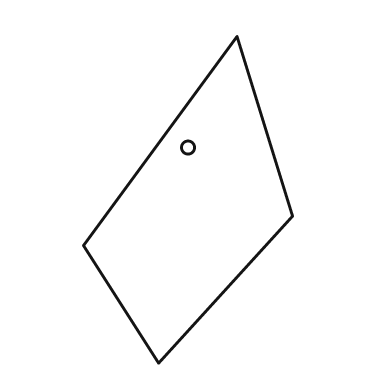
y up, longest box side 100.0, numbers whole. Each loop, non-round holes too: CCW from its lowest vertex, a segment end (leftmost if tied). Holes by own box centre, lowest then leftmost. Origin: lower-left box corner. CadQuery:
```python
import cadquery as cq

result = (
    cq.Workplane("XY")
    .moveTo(23.0, 0.0)
    .lineTo(64.0, 45.0)
    .lineTo(47.0, 100.0)
    .lineTo(0.0, 36.0)
    .close()
    .moveTo(32.0, 66.0)
    .circle(2.0)
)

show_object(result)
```